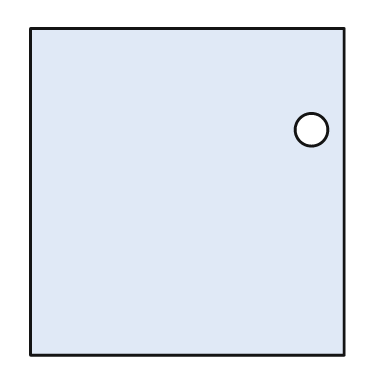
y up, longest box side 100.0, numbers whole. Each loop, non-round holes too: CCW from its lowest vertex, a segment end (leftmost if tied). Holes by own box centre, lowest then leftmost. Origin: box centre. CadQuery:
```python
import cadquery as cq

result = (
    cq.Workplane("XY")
    .moveTo(-48.0, -50.0)
    .lineTo(48.0, -50.0)
    .lineTo(48.0, 50.0)
    .lineTo(-48.0, 50.0)
    .close()
    .moveTo(38.0, 19.0)
    .circle(5.0)
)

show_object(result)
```